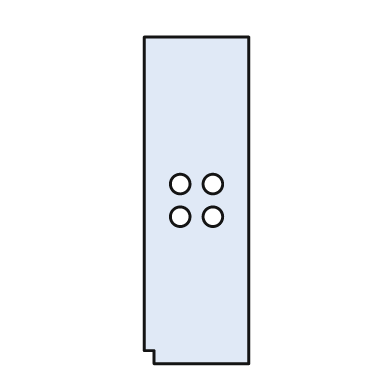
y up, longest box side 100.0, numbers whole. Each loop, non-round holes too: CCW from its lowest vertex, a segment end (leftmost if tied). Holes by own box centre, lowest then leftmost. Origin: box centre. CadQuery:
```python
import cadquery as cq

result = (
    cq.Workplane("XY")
    .moveTo(-13.0, -50.0)
    .lineTo(16.0, -50.0)
    .lineTo(16.0, 50.0)
    .lineTo(-16.0, 50.0)
    .lineTo(-16.0, -46.0)
    .lineTo(-13.0, -46.0)
    .close()
    .moveTo(-5.0, -5.0)
    .circle(3.0)
    .moveTo(5.0, -5.0)
    .circle(3.0)
    .moveTo(-5.0, 5.0)
    .circle(3.0)
    .moveTo(5.0, 5.0)
    .circle(3.0)
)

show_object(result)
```